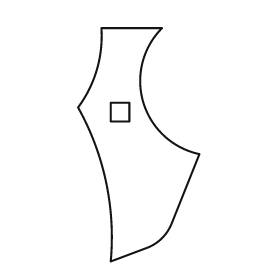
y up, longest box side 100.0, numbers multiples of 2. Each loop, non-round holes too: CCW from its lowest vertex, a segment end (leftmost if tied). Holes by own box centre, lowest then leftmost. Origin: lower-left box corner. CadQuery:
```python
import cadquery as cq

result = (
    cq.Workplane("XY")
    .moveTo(14.0, 0.0)
    .lineTo(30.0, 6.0)
    .threePointArc((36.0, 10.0), (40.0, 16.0))
    .lineTo(52.0, 46.0)
    .threePointArc((28.0, 68.0), (36.0, 100.0))
    .lineTo(10.0, 100.0)
    .threePointArc((8.0, 82.0), (0.0, 66.0))
    .threePointArc((12.0, 34.0), (14.0, 0.0))
    .close()
    .moveTo(14.0, 60.0)
    .lineTo(22.0, 60.0)
    .lineTo(22.0, 68.0)
    .lineTo(14.0, 68.0)
    .close()
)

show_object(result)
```